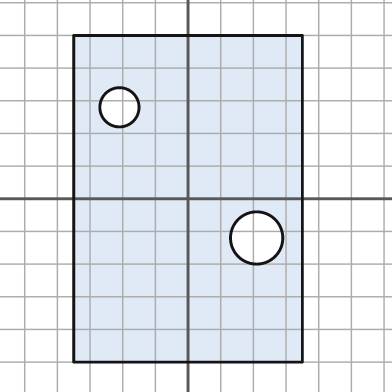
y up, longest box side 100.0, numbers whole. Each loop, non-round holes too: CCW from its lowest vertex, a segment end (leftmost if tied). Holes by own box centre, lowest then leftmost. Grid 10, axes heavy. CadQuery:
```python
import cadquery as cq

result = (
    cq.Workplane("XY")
    .moveTo(-35.0, -50.0)
    .lineTo(35.0, -50.0)
    .lineTo(35.0, 50.0)
    .lineTo(-35.0, 50.0)
    .close()
    .moveTo(21.0, -12.0)
    .circle(8.0)
    .moveTo(-21.0, 28.0)
    .circle(6.0)
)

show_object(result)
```